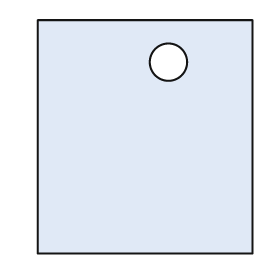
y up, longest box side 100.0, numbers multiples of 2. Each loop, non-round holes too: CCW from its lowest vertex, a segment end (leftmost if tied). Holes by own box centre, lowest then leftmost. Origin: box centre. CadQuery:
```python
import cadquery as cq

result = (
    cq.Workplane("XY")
    .moveTo(-46.0, -50.0)
    .lineTo(46.0, -50.0)
    .lineTo(46.0, 50.0)
    .lineTo(-46.0, 50.0)
    .close()
    .moveTo(10.0, 32.0)
    .circle(8.0)
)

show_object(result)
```